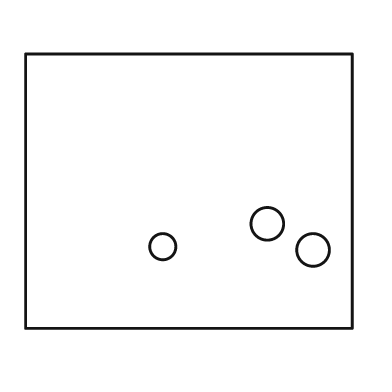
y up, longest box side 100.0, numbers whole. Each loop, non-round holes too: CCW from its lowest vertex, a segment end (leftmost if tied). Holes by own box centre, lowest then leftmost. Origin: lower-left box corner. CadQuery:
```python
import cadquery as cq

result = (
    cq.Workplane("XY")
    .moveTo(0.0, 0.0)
    .lineTo(100.0, 0.0)
    .lineTo(100.0, 84.0)
    .lineTo(0.0, 84.0)
    .close()
    .moveTo(88.0, 24.0)
    .circle(5.0)
    .moveTo(42.0, 25.0)
    .circle(4.0)
    .moveTo(74.0, 32.0)
    .circle(5.0)
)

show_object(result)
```